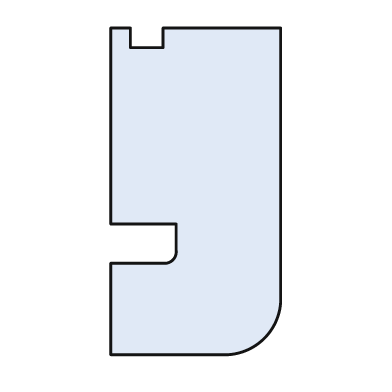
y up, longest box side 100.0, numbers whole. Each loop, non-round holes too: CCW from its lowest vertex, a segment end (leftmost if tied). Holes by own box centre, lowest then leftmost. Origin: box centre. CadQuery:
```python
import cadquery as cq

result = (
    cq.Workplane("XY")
    .moveTo(-26.0, -50.0)
    .lineTo(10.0, -50.0)
    .threePointArc((21.0, -45.0), (26.0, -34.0))
    .lineTo(26.0, 50.0)
    .lineTo(-10.0, 50.0)
    .lineTo(-10.0, 44.0)
    .lineTo(-20.0, 44.0)
    .lineTo(-20.0, 50.0)
    .lineTo(-26.0, 50.0)
    .lineTo(-26.0, -10.0)
    .lineTo(-6.0, -10.0)
    .lineTo(-6.0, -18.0)
    .threePointArc((-7.0, -21.0), (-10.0, -22.0))
    .lineTo(-26.0, -22.0)
    .close()
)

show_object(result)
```